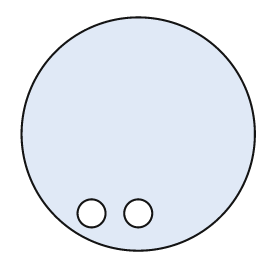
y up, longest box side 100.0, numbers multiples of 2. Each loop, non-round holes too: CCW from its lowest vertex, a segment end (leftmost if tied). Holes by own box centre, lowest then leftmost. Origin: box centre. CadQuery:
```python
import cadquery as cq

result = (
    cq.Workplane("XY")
    .moveTo(0.0, 0.0)
    .circle(50.0)
    .moveTo(-20.0, -34.0)
    .circle(6.0)
    .moveTo(0.0, -34.0)
    .circle(6.0)
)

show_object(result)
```